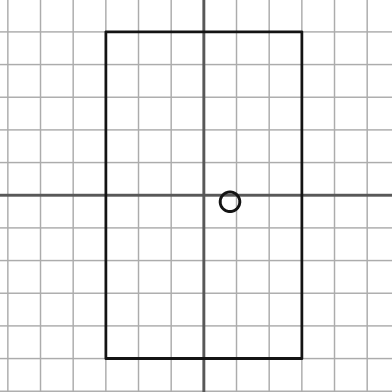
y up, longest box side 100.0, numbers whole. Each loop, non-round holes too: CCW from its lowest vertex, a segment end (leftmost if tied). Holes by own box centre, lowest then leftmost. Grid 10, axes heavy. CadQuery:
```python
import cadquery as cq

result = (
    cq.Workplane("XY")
    .moveTo(-30.0, -50.0)
    .lineTo(30.0, -50.0)
    .lineTo(30.0, 50.0)
    .lineTo(-30.0, 50.0)
    .close()
    .moveTo(8.0, -2.0)
    .circle(3.0)
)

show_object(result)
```